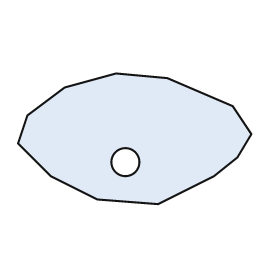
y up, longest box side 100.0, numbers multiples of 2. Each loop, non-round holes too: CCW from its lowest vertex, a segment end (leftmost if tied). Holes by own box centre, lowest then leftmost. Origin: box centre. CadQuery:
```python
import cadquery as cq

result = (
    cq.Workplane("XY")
    .moveTo(10.0, -28.0)
    .lineTo(34.0, -16.0)
    .lineTo(44.0, -8.0)
    .lineTo(50.0, 2.0)
    .lineTo(42.0, 14.0)
    .lineTo(14.0, 26.0)
    .lineTo(-8.0, 28.0)
    .lineTo(-30.0, 22.0)
    .lineTo(-46.0, 10.0)
    .lineTo(-50.0, -2.0)
    .lineTo(-36.0, -16.0)
    .lineTo(-16.0, -26.0)
    .close()
    .moveTo(-4.0, -10.0)
    .circle(6.0)
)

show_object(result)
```